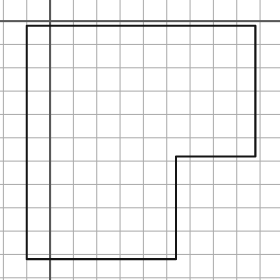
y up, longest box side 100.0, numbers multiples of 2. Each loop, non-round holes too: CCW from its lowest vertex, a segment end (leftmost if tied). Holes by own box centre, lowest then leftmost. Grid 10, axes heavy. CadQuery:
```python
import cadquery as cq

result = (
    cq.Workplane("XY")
    .moveTo(-10.0, -102.0)
    .lineTo(54.0, -102.0)
    .lineTo(54.0, -58.0)
    .lineTo(88.0, -58.0)
    .lineTo(88.0, -2.0)
    .lineTo(-10.0, -2.0)
    .close()
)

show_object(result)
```